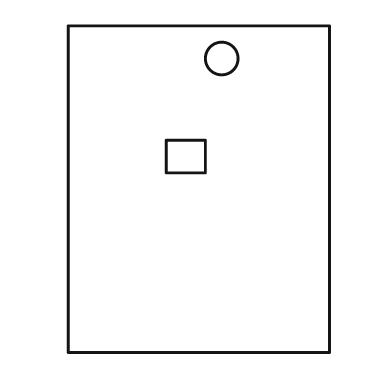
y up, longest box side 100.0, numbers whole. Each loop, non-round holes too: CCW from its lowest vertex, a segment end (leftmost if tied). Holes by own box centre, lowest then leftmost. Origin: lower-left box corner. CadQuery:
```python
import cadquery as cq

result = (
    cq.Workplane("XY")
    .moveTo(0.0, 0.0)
    .lineTo(80.0, 0.0)
    .lineTo(80.0, 100.0)
    .lineTo(0.0, 100.0)
    .close()
    .moveTo(30.0, 55.0)
    .lineTo(42.0, 55.0)
    .lineTo(42.0, 65.0)
    .lineTo(30.0, 65.0)
    .close()
    .moveTo(47.0, 90.0)
    .circle(5.0)
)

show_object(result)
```